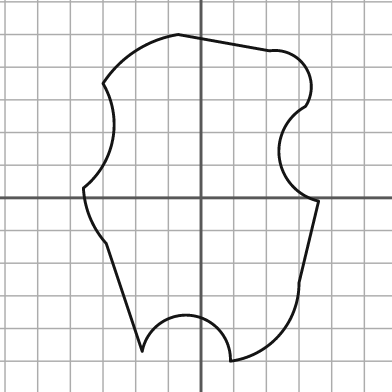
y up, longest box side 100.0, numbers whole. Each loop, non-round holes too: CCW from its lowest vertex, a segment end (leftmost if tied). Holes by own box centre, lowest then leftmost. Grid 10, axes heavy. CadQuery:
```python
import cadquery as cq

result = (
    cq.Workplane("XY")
    .moveTo(9.0, -50.0)
    .threePointArc((24.0, -42.0), (30.0, -26.0))
    .lineTo(36.0, -1.0)
    .threePointArc((24.0, 12.0), (32.0, 28.0))
    .threePointArc((32.0, 40.0), (21.0, 45.0))
    .lineTo(-7.0, 50.0)
    .threePointArc((-20.0, 45.0), (-30.0, 35.0))
    .threePointArc((-27.0, 18.0), (-36.0, 3.0))
    .threePointArc((-34.0, -6.0), (-29.0, -14.0))
    .lineTo(-18.0, -47.0)
    .threePointArc((-3.0, -36.0), (9.0, -50.0))
    .close()
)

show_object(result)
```